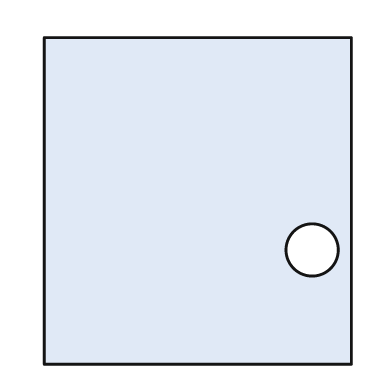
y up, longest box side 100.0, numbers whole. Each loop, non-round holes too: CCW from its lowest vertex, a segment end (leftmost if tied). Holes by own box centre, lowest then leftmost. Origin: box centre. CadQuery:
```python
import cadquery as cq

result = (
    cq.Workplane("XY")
    .moveTo(-47.0, -50.0)
    .lineTo(47.0, -50.0)
    .lineTo(47.0, 50.0)
    .lineTo(-47.0, 50.0)
    .close()
    .moveTo(35.0, -15.0)
    .circle(8.0)
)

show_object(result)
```